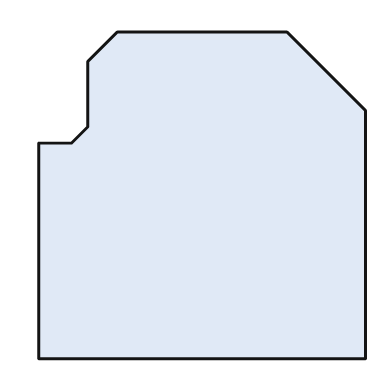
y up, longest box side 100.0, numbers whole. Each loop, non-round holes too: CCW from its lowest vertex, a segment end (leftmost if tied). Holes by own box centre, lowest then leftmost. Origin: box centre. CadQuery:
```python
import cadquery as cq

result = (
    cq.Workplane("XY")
    .moveTo(-50.0, -50.0)
    .lineTo(50.0, -50.0)
    .lineTo(50.0, 26.0)
    .lineTo(26.0, 50.0)
    .lineTo(-26.0, 50.0)
    .lineTo(-35.0, 41.0)
    .lineTo(-35.0, 21.0)
    .lineTo(-40.0, 16.0)
    .lineTo(-50.0, 16.0)
    .close()
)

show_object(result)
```